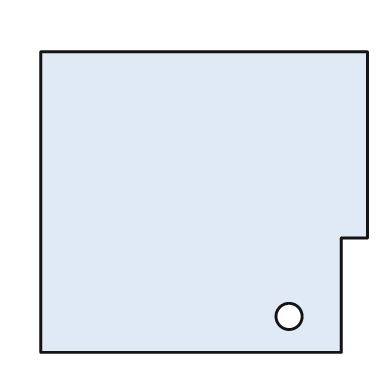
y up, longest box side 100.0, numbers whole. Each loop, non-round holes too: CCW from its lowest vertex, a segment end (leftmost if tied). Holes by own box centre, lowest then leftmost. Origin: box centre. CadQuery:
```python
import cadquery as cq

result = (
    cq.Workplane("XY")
    .moveTo(-50.0, -46.0)
    .lineTo(42.0, -46.0)
    .lineTo(42.0, -11.0)
    .lineTo(50.0, -11.0)
    .lineTo(50.0, 46.0)
    .lineTo(-50.0, 46.0)
    .close()
    .moveTo(26.0, -35.0)
    .circle(4.0)
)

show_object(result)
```